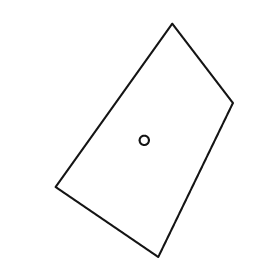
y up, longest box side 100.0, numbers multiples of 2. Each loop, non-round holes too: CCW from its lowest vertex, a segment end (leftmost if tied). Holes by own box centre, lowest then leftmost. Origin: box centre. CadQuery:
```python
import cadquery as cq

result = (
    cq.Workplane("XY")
    .moveTo(6.0, -50.0)
    .lineTo(38.0, 16.0)
    .lineTo(12.0, 50.0)
    .lineTo(-38.0, -20.0)
    .close()
    .moveTo(0.0, 0.0)
    .circle(2.0)
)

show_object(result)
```